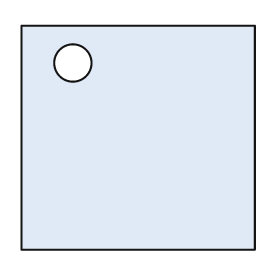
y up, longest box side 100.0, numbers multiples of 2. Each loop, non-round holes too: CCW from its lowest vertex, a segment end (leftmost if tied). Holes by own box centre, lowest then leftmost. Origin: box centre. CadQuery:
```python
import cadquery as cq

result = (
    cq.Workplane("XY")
    .moveTo(-50.0, -48.0)
    .lineTo(50.0, -48.0)
    .lineTo(50.0, 48.0)
    .lineTo(-50.0, 48.0)
    .close()
    .moveTo(-28.0, 32.0)
    .circle(8.0)
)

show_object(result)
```